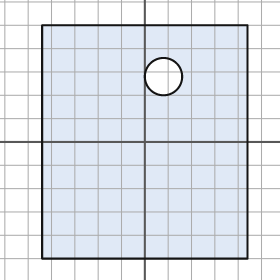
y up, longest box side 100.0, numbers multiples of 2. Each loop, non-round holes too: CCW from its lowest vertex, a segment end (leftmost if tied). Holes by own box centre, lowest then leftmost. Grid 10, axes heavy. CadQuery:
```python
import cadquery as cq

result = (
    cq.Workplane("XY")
    .moveTo(-44.0, -50.0)
    .lineTo(44.0, -50.0)
    .lineTo(44.0, 50.0)
    .lineTo(-44.0, 50.0)
    .close()
    .moveTo(8.0, 28.0)
    .circle(8.0)
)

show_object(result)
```